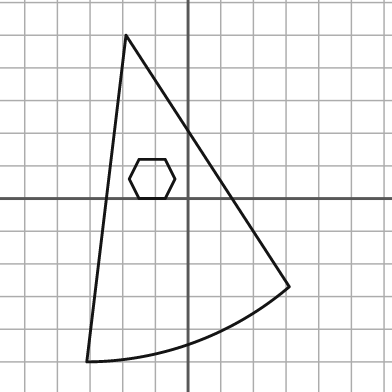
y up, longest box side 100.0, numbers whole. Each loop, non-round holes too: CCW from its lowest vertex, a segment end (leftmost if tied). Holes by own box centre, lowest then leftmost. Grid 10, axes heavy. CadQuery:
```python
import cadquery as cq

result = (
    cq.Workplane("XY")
    .moveTo(-31.0, -50.0)
    .threePointArc((2.0, -44.0), (31.0, -27.0))
    .lineTo(-19.0, 50.0)
    .close()
    .moveTo(-15.0, 0.0)
    .lineTo(-7.0, 0.0)
    .lineTo(-4.0, 6.0)
    .lineTo(-7.0, 12.0)
    .lineTo(-15.0, 12.0)
    .lineTo(-18.0, 6.0)
    .close()
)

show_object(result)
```